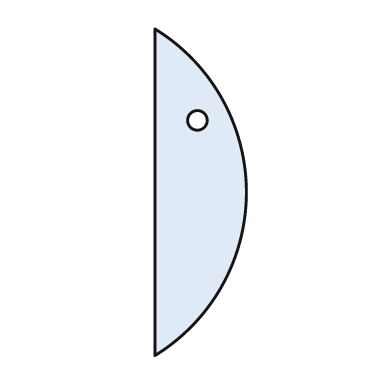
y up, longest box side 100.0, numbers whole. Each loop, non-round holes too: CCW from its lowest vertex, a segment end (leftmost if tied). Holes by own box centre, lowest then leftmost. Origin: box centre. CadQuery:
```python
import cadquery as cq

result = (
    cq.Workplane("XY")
    .moveTo(-14.0, -50.0)
    .threePointArc((14.0, 0.0), (-14.0, 50.0))
    .close()
    .moveTo(-1.0, 22.0)
    .circle(3.0)
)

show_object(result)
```